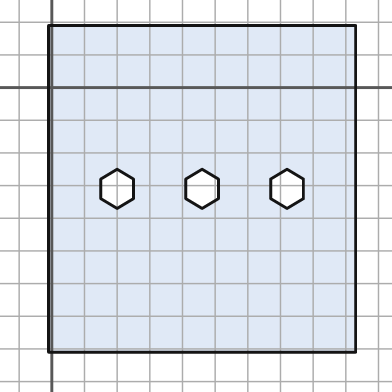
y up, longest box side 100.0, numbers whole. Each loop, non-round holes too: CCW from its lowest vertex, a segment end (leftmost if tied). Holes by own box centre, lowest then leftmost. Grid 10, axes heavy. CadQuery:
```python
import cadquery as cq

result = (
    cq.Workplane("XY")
    .moveTo(-1.0, -81.0)
    .lineTo(93.0, -81.0)
    .lineTo(93.0, 19.0)
    .lineTo(-1.0, 19.0)
    .close()
    .moveTo(20.0, -37.0)
    .lineTo(25.0, -34.0)
    .lineTo(25.0, -28.0)
    .lineTo(20.0, -25.0)
    .lineTo(15.0, -28.0)
    .lineTo(15.0, -34.0)
    .close()
    .moveTo(46.0, -37.0)
    .lineTo(51.0, -34.0)
    .lineTo(51.0, -28.0)
    .lineTo(46.0, -25.0)
    .lineTo(41.0, -28.0)
    .lineTo(41.0, -34.0)
    .close()
    .moveTo(72.0, -37.0)
    .lineTo(77.0, -34.0)
    .lineTo(77.0, -28.0)
    .lineTo(72.0, -25.0)
    .lineTo(67.0, -28.0)
    .lineTo(67.0, -34.0)
    .close()
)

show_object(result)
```